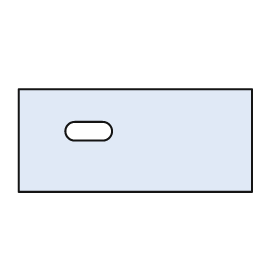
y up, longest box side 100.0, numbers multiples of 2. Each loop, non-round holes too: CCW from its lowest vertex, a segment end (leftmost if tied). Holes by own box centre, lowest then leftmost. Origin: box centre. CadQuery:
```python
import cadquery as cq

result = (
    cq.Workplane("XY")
    .moveTo(-50.0, -22.0)
    .lineTo(50.0, -22.0)
    .lineTo(50.0, 22.0)
    .lineTo(-50.0, 22.0)
    .close()
    .moveTo(-26.0, 0.0)
    .lineTo(-14.0, 0.0)
    .threePointArc((-10.0, 4.0), (-14.0, 8.0))
    .lineTo(-26.0, 8.0)
    .threePointArc((-30.0, 4.0), (-26.0, 0.0))
    .close()
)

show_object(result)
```